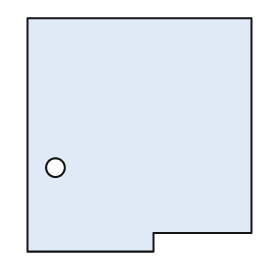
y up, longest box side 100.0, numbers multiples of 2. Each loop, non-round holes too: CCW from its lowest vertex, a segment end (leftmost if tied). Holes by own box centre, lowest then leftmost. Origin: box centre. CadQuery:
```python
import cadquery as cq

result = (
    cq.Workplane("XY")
    .moveTo(-48.0, -50.0)
    .lineTo(6.0, -50.0)
    .lineTo(6.0, -42.0)
    .lineTo(48.0, -42.0)
    .lineTo(48.0, 50.0)
    .lineTo(-48.0, 50.0)
    .close()
    .moveTo(-36.0, -14.0)
    .circle(4.0)
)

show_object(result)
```